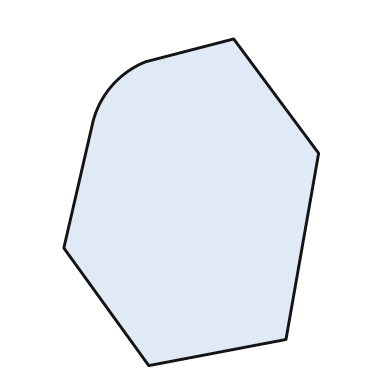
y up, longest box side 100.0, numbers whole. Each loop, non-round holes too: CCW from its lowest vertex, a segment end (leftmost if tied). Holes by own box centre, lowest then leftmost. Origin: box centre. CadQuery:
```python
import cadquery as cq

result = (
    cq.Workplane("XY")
    .moveTo(-13.0, -50.0)
    .lineTo(29.0, -42.0)
    .lineTo(39.0, 15.0)
    .lineTo(13.0, 50.0)
    .lineTo(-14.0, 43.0)
    .threePointArc((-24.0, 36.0), (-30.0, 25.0))
    .lineTo(-39.0, -14.0)
    .close()
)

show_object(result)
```